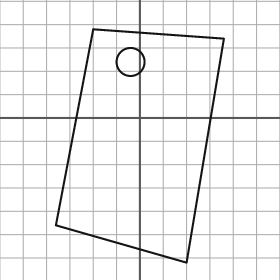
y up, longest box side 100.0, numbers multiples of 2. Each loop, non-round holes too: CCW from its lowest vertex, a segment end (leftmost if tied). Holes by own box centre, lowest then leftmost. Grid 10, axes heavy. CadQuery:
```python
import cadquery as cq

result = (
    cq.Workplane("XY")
    .moveTo(20.0, -62.0)
    .lineTo(36.0, 34.0)
    .lineTo(-20.0, 38.0)
    .lineTo(-36.0, -46.0)
    .close()
    .moveTo(-4.0, 24.0)
    .circle(6.0)
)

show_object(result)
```